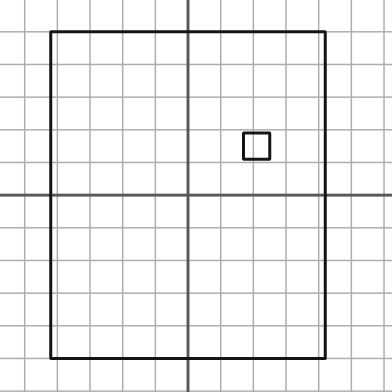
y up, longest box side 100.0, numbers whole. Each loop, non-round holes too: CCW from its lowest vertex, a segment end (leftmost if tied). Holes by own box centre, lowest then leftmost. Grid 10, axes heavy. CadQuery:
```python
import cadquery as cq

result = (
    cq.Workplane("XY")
    .moveTo(-42.0, -50.0)
    .lineTo(42.0, -50.0)
    .lineTo(42.0, 50.0)
    .lineTo(-42.0, 50.0)
    .close()
    .moveTo(17.0, 11.0)
    .lineTo(25.0, 11.0)
    .lineTo(25.0, 19.0)
    .lineTo(17.0, 19.0)
    .close()
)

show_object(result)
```